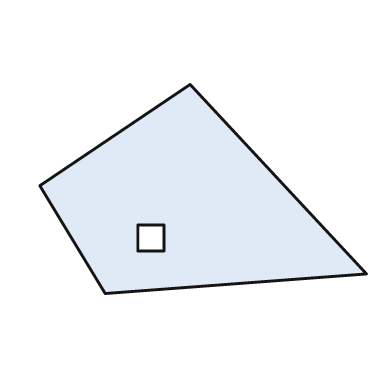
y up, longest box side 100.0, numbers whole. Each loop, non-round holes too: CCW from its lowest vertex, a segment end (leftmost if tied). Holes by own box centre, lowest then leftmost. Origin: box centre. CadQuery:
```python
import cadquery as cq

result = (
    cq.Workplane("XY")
    .moveTo(-30.0, -32.0)
    .lineTo(50.0, -26.0)
    .lineTo(-4.0, 32.0)
    .lineTo(-50.0, 1.0)
    .close()
    .moveTo(-20.0, -19.0)
    .lineTo(-12.0, -19.0)
    .lineTo(-12.0, -11.0)
    .lineTo(-20.0, -11.0)
    .close()
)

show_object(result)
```